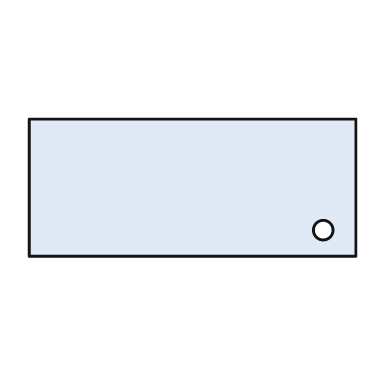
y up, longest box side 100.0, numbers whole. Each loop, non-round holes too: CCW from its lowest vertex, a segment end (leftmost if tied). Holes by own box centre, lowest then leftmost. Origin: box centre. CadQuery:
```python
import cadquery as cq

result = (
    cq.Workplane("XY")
    .moveTo(-50.0, -21.0)
    .lineTo(50.0, -21.0)
    .lineTo(50.0, 21.0)
    .lineTo(-50.0, 21.0)
    .close()
    .moveTo(40.0, -13.0)
    .circle(3.0)
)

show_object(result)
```